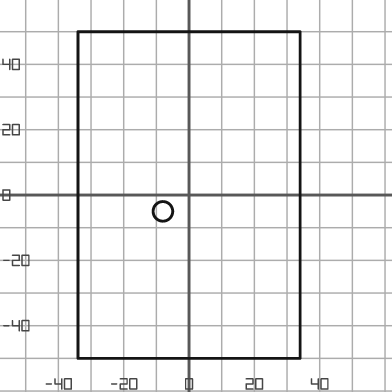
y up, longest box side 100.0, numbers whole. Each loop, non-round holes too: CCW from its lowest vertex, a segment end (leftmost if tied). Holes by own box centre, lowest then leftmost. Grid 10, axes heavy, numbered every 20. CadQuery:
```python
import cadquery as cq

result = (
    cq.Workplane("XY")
    .moveTo(-34.0, -50.0)
    .lineTo(34.0, -50.0)
    .lineTo(34.0, 50.0)
    .lineTo(-34.0, 50.0)
    .close()
    .moveTo(-8.0, -5.0)
    .circle(3.0)
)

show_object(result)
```